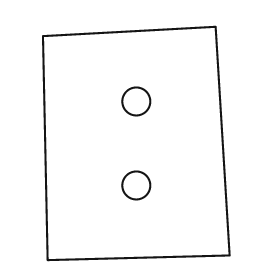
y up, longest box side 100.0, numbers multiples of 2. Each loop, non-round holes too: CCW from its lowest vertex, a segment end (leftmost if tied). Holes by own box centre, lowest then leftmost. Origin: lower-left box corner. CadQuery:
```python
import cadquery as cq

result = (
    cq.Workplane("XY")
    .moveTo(2.0, 0.0)
    .lineTo(80.0, 2.0)
    .lineTo(74.0, 100.0)
    .lineTo(0.0, 96.0)
    .close()
    .moveTo(40.0, 32.0)
    .circle(6.0)
    .moveTo(40.0, 68.0)
    .circle(6.0)
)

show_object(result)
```